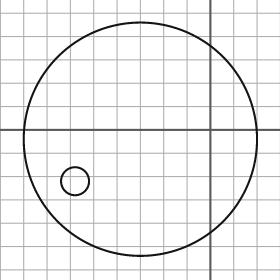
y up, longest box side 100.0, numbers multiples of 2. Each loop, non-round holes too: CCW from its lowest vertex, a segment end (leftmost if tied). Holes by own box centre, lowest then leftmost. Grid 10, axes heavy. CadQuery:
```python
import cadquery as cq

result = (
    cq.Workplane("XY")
    .moveTo(-30.0, -4.0)
    .circle(50.0)
    .moveTo(-58.0, -22.0)
    .circle(6.0)
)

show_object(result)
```